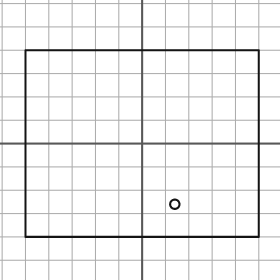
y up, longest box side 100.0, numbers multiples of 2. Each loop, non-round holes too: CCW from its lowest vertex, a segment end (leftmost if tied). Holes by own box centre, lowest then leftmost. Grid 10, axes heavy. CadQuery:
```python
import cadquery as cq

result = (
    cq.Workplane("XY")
    .moveTo(-50.0, -40.0)
    .lineTo(50.0, -40.0)
    .lineTo(50.0, 40.0)
    .lineTo(-50.0, 40.0)
    .close()
    .moveTo(14.0, -26.0)
    .circle(2.0)
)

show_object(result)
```